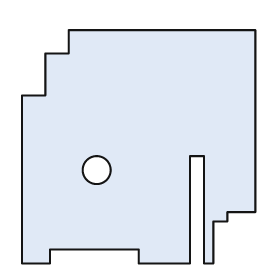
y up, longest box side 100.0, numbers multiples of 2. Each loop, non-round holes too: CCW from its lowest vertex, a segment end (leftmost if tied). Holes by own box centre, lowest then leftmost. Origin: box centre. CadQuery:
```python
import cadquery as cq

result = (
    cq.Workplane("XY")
    .moveTo(-50.0, -50.0)
    .lineTo(-38.0, -50.0)
    .lineTo(-38.0, -44.0)
    .lineTo(0.0, -44.0)
    .lineTo(0.0, -50.0)
    .lineTo(22.0, -50.0)
    .lineTo(22.0, -4.0)
    .lineTo(28.0, -4.0)
    .lineTo(28.0, -50.0)
    .lineTo(32.0, -50.0)
    .lineTo(32.0, -32.0)
    .lineTo(38.0, -32.0)
    .lineTo(38.0, -28.0)
    .lineTo(50.0, -28.0)
    .lineTo(50.0, 50.0)
    .lineTo(-30.0, 50.0)
    .lineTo(-30.0, 40.0)
    .lineTo(-40.0, 40.0)
    .lineTo(-40.0, 22.0)
    .lineTo(-50.0, 22.0)
    .close()
    .moveTo(-18.0, -10.0)
    .circle(6.0)
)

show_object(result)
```